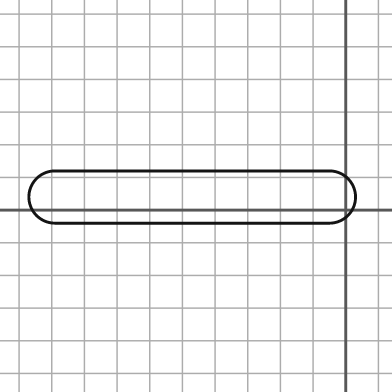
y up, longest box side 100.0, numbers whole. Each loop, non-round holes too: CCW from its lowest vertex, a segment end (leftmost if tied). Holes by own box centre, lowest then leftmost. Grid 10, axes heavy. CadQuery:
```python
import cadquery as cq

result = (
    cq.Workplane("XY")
    .moveTo(-89.0, -4.0)
    .lineTo(-5.0, -4.0)
    .threePointArc((3.0, 4.0), (-5.0, 12.0))
    .lineTo(-89.0, 12.0)
    .threePointArc((-97.0, 4.0), (-89.0, -4.0))
    .close()
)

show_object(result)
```